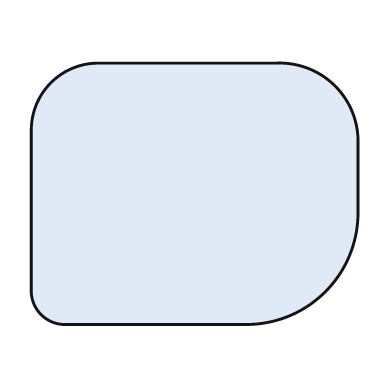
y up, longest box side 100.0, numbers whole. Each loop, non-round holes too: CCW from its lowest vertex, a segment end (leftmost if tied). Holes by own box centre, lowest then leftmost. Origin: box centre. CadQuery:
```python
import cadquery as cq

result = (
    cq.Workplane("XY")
    .moveTo(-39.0, -40.0)
    .lineTo(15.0, -40.0)
    .threePointArc((40.0, -30.0), (50.0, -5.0))
    .lineTo(50.0, 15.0)
    .threePointArc((43.0, 33.0), (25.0, 40.0))
    .lineTo(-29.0, 40.0)
    .threePointArc((-44.0, 34.0), (-50.0, 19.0))
    .lineTo(-50.0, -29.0)
    .threePointArc((-47.0, -37.0), (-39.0, -40.0))
    .close()
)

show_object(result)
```